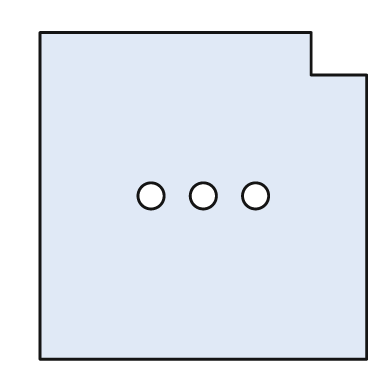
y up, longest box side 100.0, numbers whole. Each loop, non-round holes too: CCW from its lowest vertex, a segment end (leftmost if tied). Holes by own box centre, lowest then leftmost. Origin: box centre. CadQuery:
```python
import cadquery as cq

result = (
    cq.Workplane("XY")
    .moveTo(-50.0, -50.0)
    .lineTo(50.0, -50.0)
    .lineTo(50.0, 37.0)
    .lineTo(33.0, 37.0)
    .lineTo(33.0, 50.0)
    .lineTo(-50.0, 50.0)
    .close()
    .moveTo(-16.0, 0.0)
    .circle(4.0)
    .moveTo(0.0, 0.0)
    .circle(4.0)
    .moveTo(16.0, 0.0)
    .circle(4.0)
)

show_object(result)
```